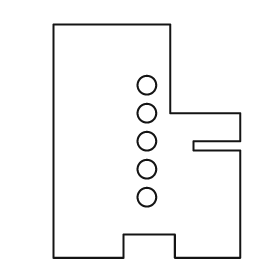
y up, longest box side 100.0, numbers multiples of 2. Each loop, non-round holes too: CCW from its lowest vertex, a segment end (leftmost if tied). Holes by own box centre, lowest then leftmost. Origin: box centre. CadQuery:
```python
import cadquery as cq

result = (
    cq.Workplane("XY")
    .moveTo(-40.0, -50.0)
    .lineTo(-10.0, -50.0)
    .lineTo(-10.0, -40.0)
    .lineTo(12.0, -40.0)
    .lineTo(12.0, -50.0)
    .lineTo(40.0, -50.0)
    .lineTo(40.0, -4.0)
    .lineTo(20.0, -4.0)
    .lineTo(20.0, 0.0)
    .lineTo(40.0, 0.0)
    .lineTo(40.0, 12.0)
    .lineTo(10.0, 12.0)
    .lineTo(10.0, 50.0)
    .lineTo(-40.0, 50.0)
    .close()
    .moveTo(0.0, -24.0)
    .circle(4.0)
    .moveTo(0.0, -12.0)
    .circle(4.0)
    .moveTo(0.0, 0.0)
    .circle(4.0)
    .moveTo(0.0, 12.0)
    .circle(4.0)
    .moveTo(0.0, 24.0)
    .circle(4.0)
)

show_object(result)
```